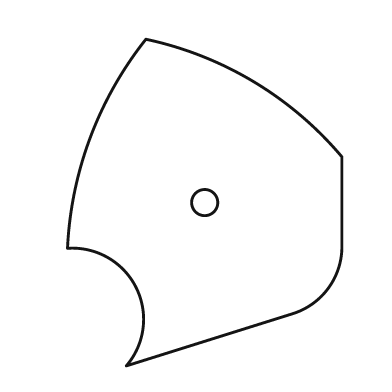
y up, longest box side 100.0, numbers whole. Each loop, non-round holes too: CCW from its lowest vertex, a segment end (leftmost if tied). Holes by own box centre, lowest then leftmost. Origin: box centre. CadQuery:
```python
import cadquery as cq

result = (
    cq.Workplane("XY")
    .moveTo(-24.0, -50.0)
    .lineTo(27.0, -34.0)
    .threePointArc((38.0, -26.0), (42.0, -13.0))
    .lineTo(42.0, 14.0)
    .threePointArc((15.0, 37.0), (-18.0, 50.0))
    .threePointArc((-35.0, 20.0), (-42.0, -14.0))
    .threePointArc((-21.0, -26.0), (-24.0, -50.0))
    .close()
    .moveTo(0.0, 0.0)
    .circle(4.0)
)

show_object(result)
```